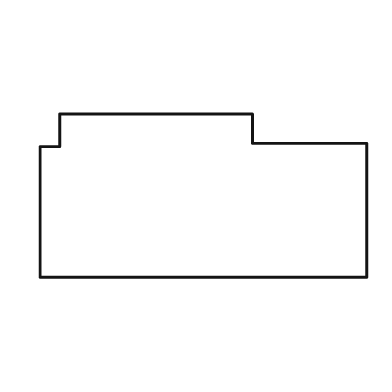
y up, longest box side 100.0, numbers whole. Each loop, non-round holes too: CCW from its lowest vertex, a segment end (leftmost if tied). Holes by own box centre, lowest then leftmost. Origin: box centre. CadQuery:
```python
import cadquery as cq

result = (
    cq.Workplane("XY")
    .moveTo(-50.0, -25.0)
    .lineTo(50.0, -25.0)
    .lineTo(50.0, 16.0)
    .lineTo(15.0, 16.0)
    .lineTo(15.0, 25.0)
    .lineTo(-44.0, 25.0)
    .lineTo(-44.0, 15.0)
    .lineTo(-50.0, 15.0)
    .close()
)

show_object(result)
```